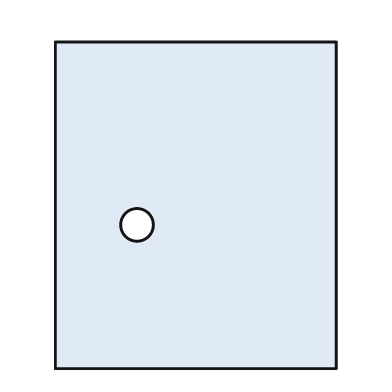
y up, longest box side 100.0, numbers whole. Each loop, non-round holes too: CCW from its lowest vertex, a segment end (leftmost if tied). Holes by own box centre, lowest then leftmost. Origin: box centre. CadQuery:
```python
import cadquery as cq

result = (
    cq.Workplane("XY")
    .moveTo(-43.0, -50.0)
    .lineTo(43.0, -50.0)
    .lineTo(43.0, 50.0)
    .lineTo(-43.0, 50.0)
    .close()
    .moveTo(-18.0, -6.0)
    .circle(5.0)
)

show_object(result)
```